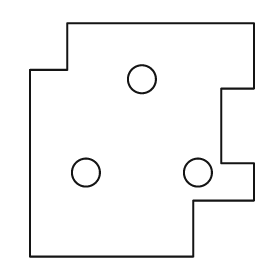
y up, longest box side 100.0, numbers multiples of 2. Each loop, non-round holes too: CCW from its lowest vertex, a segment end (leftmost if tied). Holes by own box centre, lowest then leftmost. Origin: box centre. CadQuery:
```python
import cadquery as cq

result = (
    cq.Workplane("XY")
    .moveTo(-48.0, -50.0)
    .lineTo(22.0, -50.0)
    .lineTo(22.0, -26.0)
    .lineTo(48.0, -26.0)
    .lineTo(48.0, -10.0)
    .lineTo(34.0, -10.0)
    .lineTo(34.0, 22.0)
    .lineTo(48.0, 22.0)
    .lineTo(48.0, 50.0)
    .lineTo(-32.0, 50.0)
    .lineTo(-32.0, 30.0)
    .lineTo(-48.0, 30.0)
    .close()
    .moveTo(-24.0, -14.0)
    .circle(6.0)
    .moveTo(24.0, -14.0)
    .circle(6.0)
    .moveTo(0.0, 26.0)
    .circle(6.0)
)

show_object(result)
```